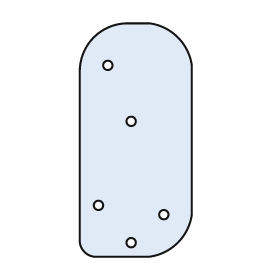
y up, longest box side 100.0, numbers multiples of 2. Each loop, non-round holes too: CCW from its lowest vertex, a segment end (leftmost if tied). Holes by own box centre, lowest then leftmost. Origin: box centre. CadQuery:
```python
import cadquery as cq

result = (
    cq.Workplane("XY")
    .moveTo(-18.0, -50.0)
    .lineTo(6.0, -50.0)
    .threePointArc((18.0, -44.0), (24.0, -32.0))
    .lineTo(24.0, 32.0)
    .threePointArc((18.0, 44.0), (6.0, 50.0))
    .lineTo(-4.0, 50.0)
    .threePointArc((-18.0, 44.0), (-24.0, 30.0))
    .lineTo(-24.0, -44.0)
    .threePointArc((-22.0, -48.0), (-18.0, -50.0))
    .close()
    .moveTo(-2.0, -44.0)
    .circle(2.0)
    .moveTo(12.0, -32.0)
    .circle(2.0)
    .moveTo(-16.0, -28.0)
    .circle(2.0)
    .moveTo(-2.0, 8.0)
    .circle(2.0)
    .moveTo(-12.0, 32.0)
    .circle(2.0)
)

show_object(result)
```